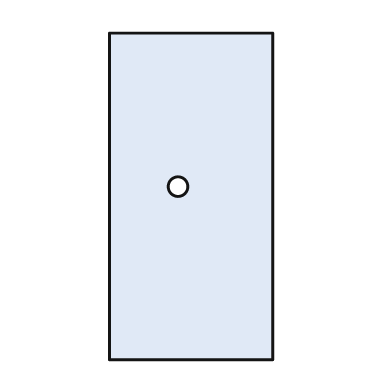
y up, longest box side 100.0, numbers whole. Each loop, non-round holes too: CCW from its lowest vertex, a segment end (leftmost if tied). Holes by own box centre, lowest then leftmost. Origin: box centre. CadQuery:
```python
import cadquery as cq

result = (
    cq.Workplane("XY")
    .moveTo(-25.0, -50.0)
    .lineTo(25.0, -50.0)
    .lineTo(25.0, 50.0)
    .lineTo(-25.0, 50.0)
    .close()
    .moveTo(-4.0, 3.0)
    .circle(3.0)
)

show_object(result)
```